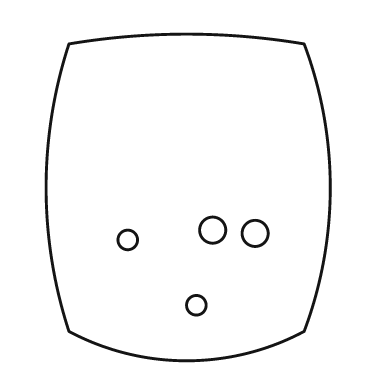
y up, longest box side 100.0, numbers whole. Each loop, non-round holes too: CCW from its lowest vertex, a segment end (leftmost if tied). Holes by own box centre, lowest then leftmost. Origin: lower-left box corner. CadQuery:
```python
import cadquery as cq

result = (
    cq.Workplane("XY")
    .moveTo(7.0, 9.0)
    .threePointArc((43.0, 0.0), (79.0, 9.0))
    .threePointArc((87.0, 53.0), (79.0, 97.0))
    .threePointArc((43.0, 100.0), (7.0, 97.0))
    .threePointArc((0.0, 53.0), (7.0, 9.0))
    .close()
    .moveTo(46.0, 17.0)
    .circle(3.0)
    .moveTo(25.0, 37.0)
    .circle(3.0)
    .moveTo(64.0, 39.0)
    .circle(4.0)
    .moveTo(51.0, 40.0)
    .circle(4.0)
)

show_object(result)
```